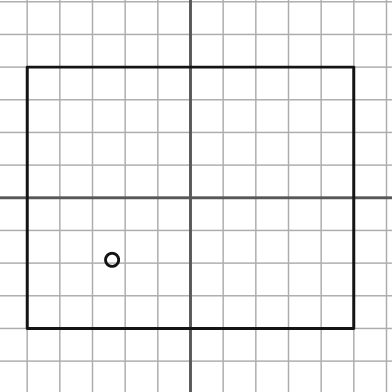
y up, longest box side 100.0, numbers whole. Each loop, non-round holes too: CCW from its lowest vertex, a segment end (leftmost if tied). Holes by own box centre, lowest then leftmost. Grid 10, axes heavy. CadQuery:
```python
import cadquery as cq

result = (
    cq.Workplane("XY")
    .moveTo(-50.0, -40.0)
    .lineTo(50.0, -40.0)
    .lineTo(50.0, 40.0)
    .lineTo(-50.0, 40.0)
    .close()
    .moveTo(-24.0, -19.0)
    .circle(2.0)
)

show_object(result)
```